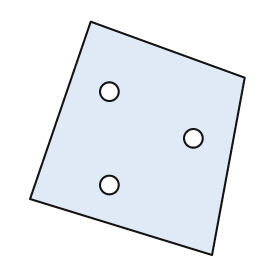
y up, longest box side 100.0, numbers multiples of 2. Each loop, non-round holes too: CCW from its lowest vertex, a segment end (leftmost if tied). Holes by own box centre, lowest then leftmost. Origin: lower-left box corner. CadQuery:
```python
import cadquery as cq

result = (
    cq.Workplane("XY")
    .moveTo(78.0, 0.0)
    .lineTo(92.0, 76.0)
    .lineTo(26.0, 100.0)
    .lineTo(0.0, 24.0)
    .close()
    .moveTo(34.0, 30.0)
    .circle(4.0)
    .moveTo(70.0, 50.0)
    .circle(4.0)
    .moveTo(34.0, 70.0)
    .circle(4.0)
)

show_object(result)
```